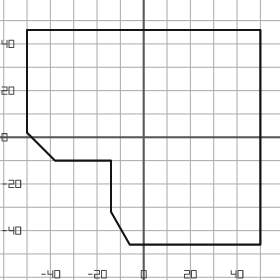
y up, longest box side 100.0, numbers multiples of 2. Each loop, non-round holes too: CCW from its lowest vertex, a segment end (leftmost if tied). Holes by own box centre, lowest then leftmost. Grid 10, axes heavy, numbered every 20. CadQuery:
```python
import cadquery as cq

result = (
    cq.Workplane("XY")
    .moveTo(-6.0, -46.0)
    .lineTo(50.0, -46.0)
    .lineTo(50.0, 46.0)
    .lineTo(-50.0, 46.0)
    .lineTo(-50.0, 2.0)
    .lineTo(-38.0, -10.0)
    .lineTo(-14.0, -10.0)
    .lineTo(-14.0, -32.0)
    .close()
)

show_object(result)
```